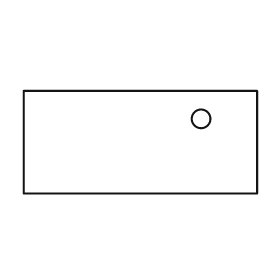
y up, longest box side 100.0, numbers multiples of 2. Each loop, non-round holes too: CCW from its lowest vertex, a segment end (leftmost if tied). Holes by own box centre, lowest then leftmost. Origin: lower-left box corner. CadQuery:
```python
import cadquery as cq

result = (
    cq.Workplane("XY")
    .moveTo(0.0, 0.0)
    .lineTo(100.0, 0.0)
    .lineTo(100.0, 44.0)
    .lineTo(0.0, 44.0)
    .close()
    .moveTo(76.0, 32.0)
    .circle(4.0)
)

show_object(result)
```